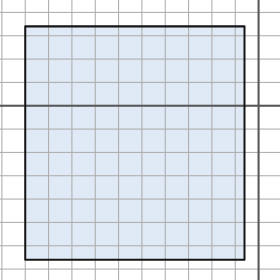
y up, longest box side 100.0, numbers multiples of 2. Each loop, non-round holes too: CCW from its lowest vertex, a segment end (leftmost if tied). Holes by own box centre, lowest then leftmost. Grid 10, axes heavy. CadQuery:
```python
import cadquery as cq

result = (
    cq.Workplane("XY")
    .moveTo(-100.0, -66.0)
    .lineTo(-6.0, -66.0)
    .lineTo(-6.0, 34.0)
    .lineTo(-100.0, 34.0)
    .close()
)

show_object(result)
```